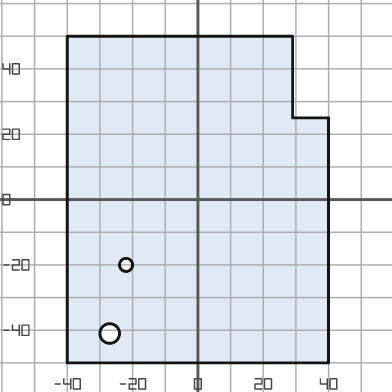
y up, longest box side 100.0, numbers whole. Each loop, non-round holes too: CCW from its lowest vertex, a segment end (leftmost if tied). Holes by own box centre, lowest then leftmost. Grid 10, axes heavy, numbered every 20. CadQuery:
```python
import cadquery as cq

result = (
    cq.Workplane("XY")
    .moveTo(-40.0, -50.0)
    .lineTo(40.0, -50.0)
    .lineTo(40.0, 25.0)
    .lineTo(29.0, 25.0)
    .lineTo(29.0, 50.0)
    .lineTo(-40.0, 50.0)
    .close()
    .moveTo(-27.0, -41.0)
    .circle(3.0)
    .moveTo(-22.0, -20.0)
    .circle(2.0)
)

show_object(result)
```